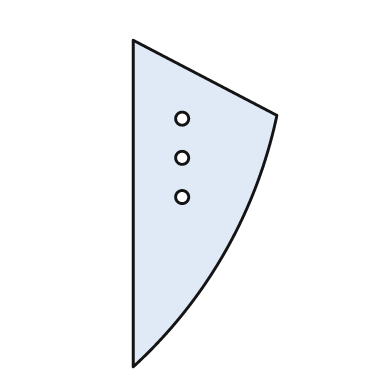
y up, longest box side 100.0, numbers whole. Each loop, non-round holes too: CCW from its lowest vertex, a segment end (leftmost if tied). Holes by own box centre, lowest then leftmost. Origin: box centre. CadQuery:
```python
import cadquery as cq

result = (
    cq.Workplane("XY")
    .moveTo(-22.0, -50.0)
    .threePointArc((6.0, -15.0), (22.0, 27.0))
    .lineTo(-22.0, 50.0)
    .close()
    .moveTo(-7.0, 2.0)
    .circle(2.0)
    .moveTo(-7.0, 14.0)
    .circle(2.0)
    .moveTo(-7.0, 26.0)
    .circle(2.0)
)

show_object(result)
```